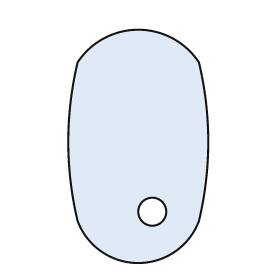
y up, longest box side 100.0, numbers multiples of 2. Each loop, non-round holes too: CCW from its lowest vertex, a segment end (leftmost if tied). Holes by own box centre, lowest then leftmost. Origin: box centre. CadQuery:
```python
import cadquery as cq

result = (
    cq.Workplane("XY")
    .moveTo(-26.0, -32.0)
    .threePointArc((0.0, -50.0), (26.0, -32.0))
    .threePointArc((30.0, 2.0), (26.0, 36.0))
    .threePointArc((0.0, 50.0), (-26.0, 36.0))
    .threePointArc((-30.0, 2.0), (-26.0, -32.0))
    .close()
    .moveTo(6.0, -28.0)
    .circle(6.0)
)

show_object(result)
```